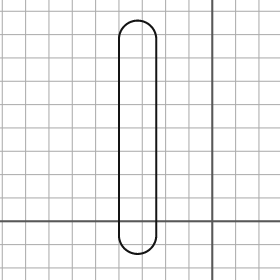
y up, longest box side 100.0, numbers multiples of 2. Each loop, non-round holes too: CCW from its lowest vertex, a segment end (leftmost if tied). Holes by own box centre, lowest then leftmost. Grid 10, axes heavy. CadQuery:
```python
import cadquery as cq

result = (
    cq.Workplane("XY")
    .moveTo(-40.0, -6.0)
    .threePointArc((-32.0, -14.0), (-24.0, -6.0))
    .lineTo(-24.0, 78.0)
    .threePointArc((-32.0, 86.0), (-40.0, 78.0))
    .close()
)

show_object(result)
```